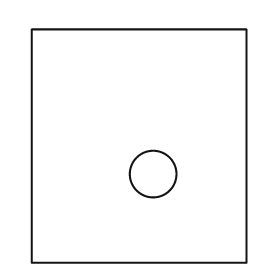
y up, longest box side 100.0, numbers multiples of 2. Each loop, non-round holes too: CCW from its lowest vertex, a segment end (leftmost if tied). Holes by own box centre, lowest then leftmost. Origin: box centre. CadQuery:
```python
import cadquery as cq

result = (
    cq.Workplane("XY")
    .moveTo(-46.0, -50.0)
    .lineTo(46.0, -50.0)
    .lineTo(46.0, 50.0)
    .lineTo(-46.0, 50.0)
    .close()
    .moveTo(6.0, -12.0)
    .circle(10.0)
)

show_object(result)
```